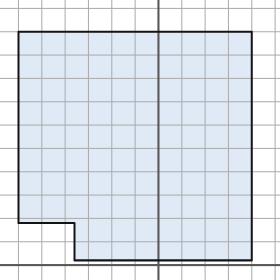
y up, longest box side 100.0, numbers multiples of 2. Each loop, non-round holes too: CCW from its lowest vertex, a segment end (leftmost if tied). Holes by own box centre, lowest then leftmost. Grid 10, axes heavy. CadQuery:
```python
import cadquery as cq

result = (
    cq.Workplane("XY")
    .moveTo(-36.0, 2.0)
    .lineTo(40.0, 2.0)
    .lineTo(40.0, 100.0)
    .lineTo(-60.0, 100.0)
    .lineTo(-60.0, 18.0)
    .lineTo(-36.0, 18.0)
    .close()
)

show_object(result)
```